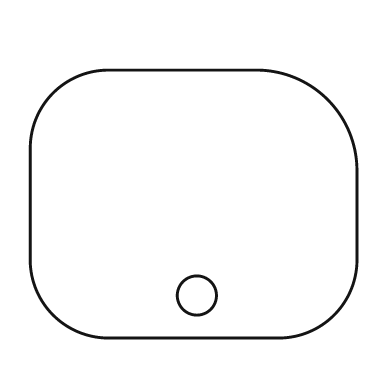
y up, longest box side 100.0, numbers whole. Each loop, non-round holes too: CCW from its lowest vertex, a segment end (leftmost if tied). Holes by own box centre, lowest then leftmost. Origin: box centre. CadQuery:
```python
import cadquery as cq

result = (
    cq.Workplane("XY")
    .moveTo(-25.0, -41.0)
    .lineTo(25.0, -41.0)
    .threePointArc((43.0, -34.0), (50.0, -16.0))
    .lineTo(50.0, 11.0)
    .threePointArc((41.0, 32.0), (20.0, 41.0))
    .lineTo(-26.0, 41.0)
    .threePointArc((-43.0, 34.0), (-50.0, 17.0))
    .lineTo(-50.0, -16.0)
    .threePointArc((-43.0, -34.0), (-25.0, -41.0))
    .close()
    .moveTo(1.0, -28.0)
    .circle(6.0)
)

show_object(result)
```